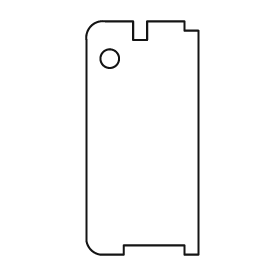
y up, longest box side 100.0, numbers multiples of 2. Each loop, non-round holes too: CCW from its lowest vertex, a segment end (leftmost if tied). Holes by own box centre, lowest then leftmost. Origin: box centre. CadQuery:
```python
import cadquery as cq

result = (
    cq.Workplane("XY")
    .moveTo(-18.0, -50.0)
    .lineTo(-8.0, -50.0)
    .lineTo(-8.0, -46.0)
    .lineTo(18.0, -46.0)
    .lineTo(18.0, -50.0)
    .lineTo(24.0, -50.0)
    .lineTo(24.0, 46.0)
    .lineTo(18.0, 46.0)
    .lineTo(18.0, 50.0)
    .lineTo(2.0, 50.0)
    .lineTo(2.0, 42.0)
    .lineTo(-4.0, 42.0)
    .lineTo(-4.0, 50.0)
    .lineTo(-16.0, 50.0)
    .threePointArc((-22.0, 48.0), (-24.0, 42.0))
    .lineTo(-24.0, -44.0)
    .threePointArc((-22.0, -48.0), (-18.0, -50.0))
    .close()
    .moveTo(-14.0, 34.0)
    .circle(4.0)
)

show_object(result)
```